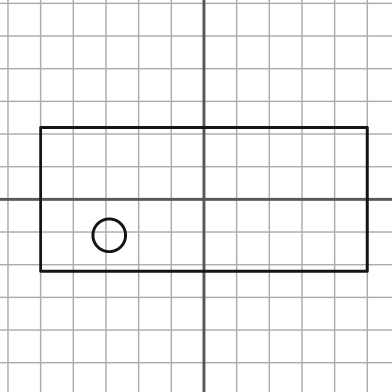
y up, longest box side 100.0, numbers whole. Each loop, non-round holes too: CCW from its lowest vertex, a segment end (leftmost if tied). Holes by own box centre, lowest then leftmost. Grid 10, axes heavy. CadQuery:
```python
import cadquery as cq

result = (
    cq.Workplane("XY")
    .moveTo(-50.0, -22.0)
    .lineTo(50.0, -22.0)
    .lineTo(50.0, 22.0)
    .lineTo(-50.0, 22.0)
    .close()
    .moveTo(-29.0, -11.0)
    .circle(5.0)
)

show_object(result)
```